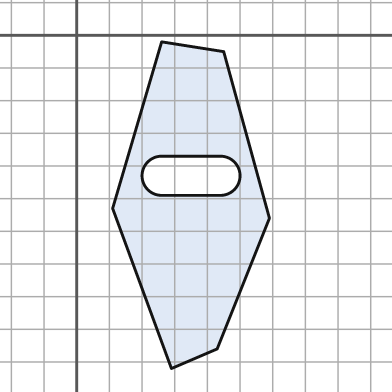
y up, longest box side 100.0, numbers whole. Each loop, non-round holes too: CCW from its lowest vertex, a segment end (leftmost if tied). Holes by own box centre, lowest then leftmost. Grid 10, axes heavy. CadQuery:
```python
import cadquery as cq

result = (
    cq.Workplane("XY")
    .moveTo(29.0, -102.0)
    .lineTo(43.0, -96.0)
    .lineTo(59.0, -56.0)
    .lineTo(45.0, -5.0)
    .lineTo(26.0, -2.0)
    .lineTo(11.0, -53.0)
    .close()
    .moveTo(26.0, -49.0)
    .lineTo(44.0, -49.0)
    .threePointArc((50.0, -43.0), (44.0, -37.0))
    .lineTo(26.0, -37.0)
    .threePointArc((20.0, -43.0), (26.0, -49.0))
    .close()
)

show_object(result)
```